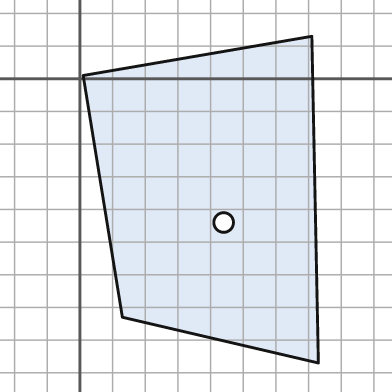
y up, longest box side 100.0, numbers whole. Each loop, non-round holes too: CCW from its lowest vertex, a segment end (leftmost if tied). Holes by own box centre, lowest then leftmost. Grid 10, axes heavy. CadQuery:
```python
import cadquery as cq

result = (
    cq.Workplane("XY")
    .moveTo(73.0, -87.0)
    .lineTo(71.0, 13.0)
    .lineTo(1.0, 1.0)
    .lineTo(13.0, -73.0)
    .close()
    .moveTo(44.0, -44.0)
    .circle(3.0)
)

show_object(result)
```